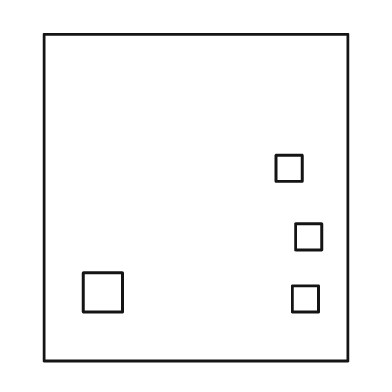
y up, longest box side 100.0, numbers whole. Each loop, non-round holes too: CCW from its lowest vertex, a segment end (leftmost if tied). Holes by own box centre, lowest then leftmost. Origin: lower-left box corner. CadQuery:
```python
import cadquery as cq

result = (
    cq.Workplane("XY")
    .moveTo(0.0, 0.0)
    .lineTo(93.0, 0.0)
    .lineTo(93.0, 100.0)
    .lineTo(0.0, 100.0)
    .close()
    .moveTo(76.0, 15.0)
    .lineTo(84.0, 15.0)
    .lineTo(84.0, 23.0)
    .lineTo(76.0, 23.0)
    .close()
    .moveTo(12.0, 15.0)
    .lineTo(24.0, 15.0)
    .lineTo(24.0, 27.0)
    .lineTo(12.0, 27.0)
    .close()
    .moveTo(77.0, 34.0)
    .lineTo(85.0, 34.0)
    .lineTo(85.0, 42.0)
    .lineTo(77.0, 42.0)
    .close()
    .moveTo(71.0, 55.0)
    .lineTo(79.0, 55.0)
    .lineTo(79.0, 63.0)
    .lineTo(71.0, 63.0)
    .close()
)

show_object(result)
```